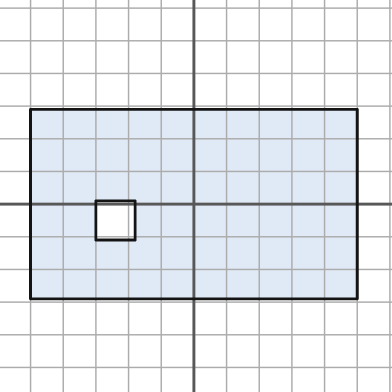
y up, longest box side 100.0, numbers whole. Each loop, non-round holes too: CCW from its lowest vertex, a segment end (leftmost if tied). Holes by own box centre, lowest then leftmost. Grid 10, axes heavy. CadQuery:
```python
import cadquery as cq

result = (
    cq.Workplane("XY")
    .moveTo(-50.0, -29.0)
    .lineTo(50.0, -29.0)
    .lineTo(50.0, 29.0)
    .lineTo(-50.0, 29.0)
    .close()
    .moveTo(-30.0, -11.0)
    .lineTo(-18.0, -11.0)
    .lineTo(-18.0, 1.0)
    .lineTo(-30.0, 1.0)
    .close()
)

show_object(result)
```